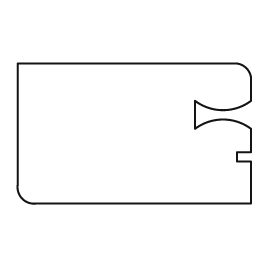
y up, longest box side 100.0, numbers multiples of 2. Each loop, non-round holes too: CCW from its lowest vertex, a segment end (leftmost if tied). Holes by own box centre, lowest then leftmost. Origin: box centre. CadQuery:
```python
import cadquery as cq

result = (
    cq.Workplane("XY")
    .moveTo(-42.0, -30.0)
    .lineTo(50.0, -30.0)
    .lineTo(50.0, -12.0)
    .lineTo(44.0, -12.0)
    .lineTo(44.0, -8.0)
    .lineTo(50.0, -8.0)
    .lineTo(50.0, 2.0)
    .threePointArc((38.0, 6.0), (26.0, 2.0))
    .lineTo(26.0, 14.0)
    .threePointArc((38.0, 10.0), (50.0, 14.0))
    .lineTo(50.0, 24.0)
    .threePointArc((48.0, 28.0), (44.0, 30.0))
    .lineTo(-50.0, 30.0)
    .lineTo(-50.0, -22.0)
    .threePointArc((-48.0, -28.0), (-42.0, -30.0))
    .close()
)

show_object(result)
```